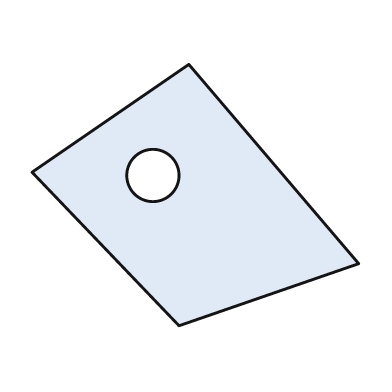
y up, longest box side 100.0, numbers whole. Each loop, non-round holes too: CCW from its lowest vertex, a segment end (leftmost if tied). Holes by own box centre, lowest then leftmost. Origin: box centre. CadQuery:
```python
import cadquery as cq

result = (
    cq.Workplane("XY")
    .moveTo(-5.0, -40.0)
    .lineTo(50.0, -21.0)
    .lineTo(-2.0, 40.0)
    .lineTo(-50.0, 7.0)
    .close()
    .moveTo(-13.0, 6.0)
    .circle(8.0)
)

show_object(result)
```